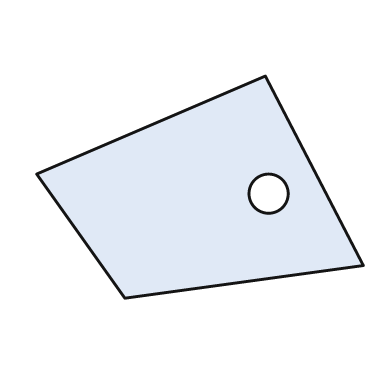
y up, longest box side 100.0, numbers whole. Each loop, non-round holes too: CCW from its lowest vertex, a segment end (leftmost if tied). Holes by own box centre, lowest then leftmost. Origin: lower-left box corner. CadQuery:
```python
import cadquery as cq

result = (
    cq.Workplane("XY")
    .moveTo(27.0, 0.0)
    .lineTo(100.0, 10.0)
    .lineTo(70.0, 68.0)
    .lineTo(0.0, 38.0)
    .close()
    .moveTo(71.0, 32.0)
    .circle(6.0)
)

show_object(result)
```